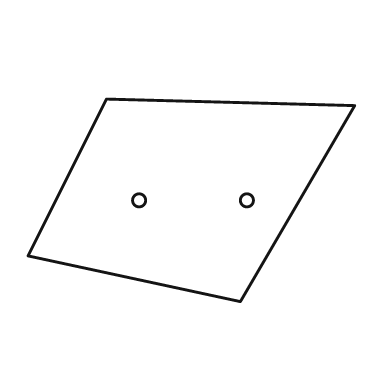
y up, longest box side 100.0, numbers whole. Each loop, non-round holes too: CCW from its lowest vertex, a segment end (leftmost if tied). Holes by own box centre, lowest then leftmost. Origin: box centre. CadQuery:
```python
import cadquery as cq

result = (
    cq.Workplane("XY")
    .moveTo(15.0, -31.0)
    .lineTo(50.0, 29.0)
    .lineTo(-26.0, 31.0)
    .lineTo(-50.0, -17.0)
    .close()
    .moveTo(-16.0, 0.0)
    .circle(2.0)
    .moveTo(17.0, 0.0)
    .circle(2.0)
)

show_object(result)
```